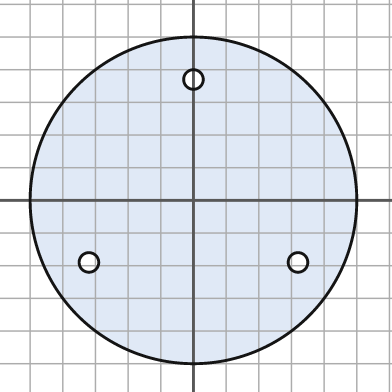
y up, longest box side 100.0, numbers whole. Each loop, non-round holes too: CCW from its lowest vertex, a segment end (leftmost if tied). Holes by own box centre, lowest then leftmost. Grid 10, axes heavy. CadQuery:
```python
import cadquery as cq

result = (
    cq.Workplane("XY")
    .moveTo(0.0, 0.0)
    .circle(50.0)
    .moveTo(-32.0, -19.0)
    .circle(3.0)
    .moveTo(32.0, -19.0)
    .circle(3.0)
    .moveTo(0.0, 37.0)
    .circle(3.0)
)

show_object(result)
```